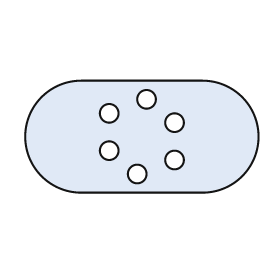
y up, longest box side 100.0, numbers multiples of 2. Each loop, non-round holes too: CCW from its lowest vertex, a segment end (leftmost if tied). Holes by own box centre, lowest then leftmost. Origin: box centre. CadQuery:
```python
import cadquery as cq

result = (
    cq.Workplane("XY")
    .moveTo(-26.0, -24.0)
    .lineTo(26.0, -24.0)
    .threePointArc((50.0, 0.0), (26.0, 24.0))
    .lineTo(-26.0, 24.0)
    .threePointArc((-50.0, 0.0), (-26.0, -24.0))
    .close()
    .moveTo(-2.0, -16.0)
    .circle(4.0)
    .moveTo(14.0, -10.0)
    .circle(4.0)
    .moveTo(-14.0, -6.0)
    .circle(4.0)
    .moveTo(14.0, 6.0)
    .circle(4.0)
    .moveTo(-14.0, 10.0)
    .circle(4.0)
    .moveTo(2.0, 16.0)
    .circle(4.0)
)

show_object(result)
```